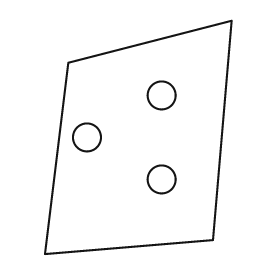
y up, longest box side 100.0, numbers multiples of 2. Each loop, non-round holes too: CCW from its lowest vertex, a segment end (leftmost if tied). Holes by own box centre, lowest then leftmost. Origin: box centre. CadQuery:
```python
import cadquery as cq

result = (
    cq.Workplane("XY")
    .moveTo(-40.0, -50.0)
    .lineTo(32.0, -44.0)
    .lineTo(40.0, 50.0)
    .lineTo(-30.0, 32.0)
    .close()
    .moveTo(10.0, -18.0)
    .circle(6.0)
    .moveTo(-22.0, 0.0)
    .circle(6.0)
    .moveTo(10.0, 18.0)
    .circle(6.0)
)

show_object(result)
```